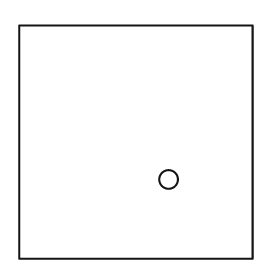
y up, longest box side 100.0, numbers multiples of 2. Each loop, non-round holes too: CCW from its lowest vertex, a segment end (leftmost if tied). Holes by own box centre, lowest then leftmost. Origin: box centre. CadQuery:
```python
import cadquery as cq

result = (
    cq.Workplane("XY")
    .moveTo(-50.0, -50.0)
    .lineTo(50.0, -50.0)
    .lineTo(50.0, 50.0)
    .lineTo(-50.0, 50.0)
    .close()
    .moveTo(14.0, -16.0)
    .circle(4.0)
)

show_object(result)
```